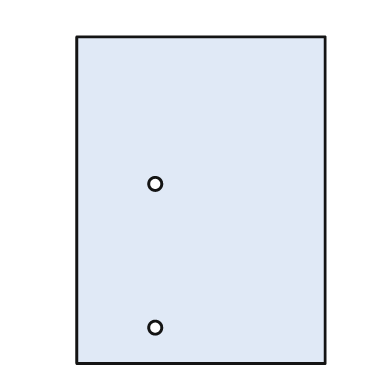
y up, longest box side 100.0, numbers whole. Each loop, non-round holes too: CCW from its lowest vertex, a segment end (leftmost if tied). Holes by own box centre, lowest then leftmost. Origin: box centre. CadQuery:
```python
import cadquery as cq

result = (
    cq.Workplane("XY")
    .moveTo(-38.0, -50.0)
    .lineTo(38.0, -50.0)
    .lineTo(38.0, 50.0)
    .lineTo(-38.0, 50.0)
    .close()
    .moveTo(-14.0, -39.0)
    .circle(2.0)
    .moveTo(-14.0, 5.0)
    .circle(2.0)
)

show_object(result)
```